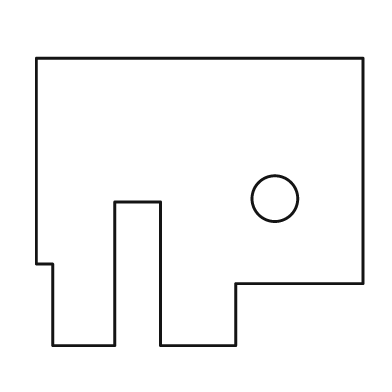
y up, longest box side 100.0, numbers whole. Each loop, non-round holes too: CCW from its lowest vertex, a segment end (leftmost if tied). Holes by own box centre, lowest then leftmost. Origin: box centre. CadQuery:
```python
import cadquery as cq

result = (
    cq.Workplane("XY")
    .moveTo(-45.0, -44.0)
    .lineTo(-26.0, -44.0)
    .lineTo(-26.0, 0.0)
    .lineTo(-12.0, 0.0)
    .lineTo(-12.0, -44.0)
    .lineTo(11.0, -44.0)
    .lineTo(11.0, -25.0)
    .lineTo(50.0, -25.0)
    .lineTo(50.0, 44.0)
    .lineTo(-50.0, 44.0)
    .lineTo(-50.0, -19.0)
    .lineTo(-45.0, -19.0)
    .close()
    .moveTo(23.0, 1.0)
    .circle(7.0)
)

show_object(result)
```